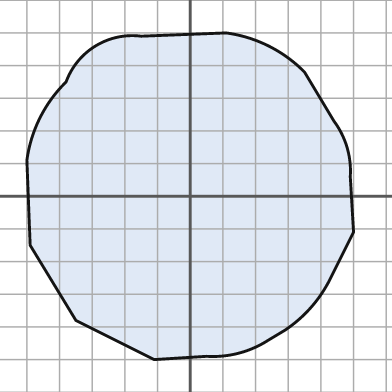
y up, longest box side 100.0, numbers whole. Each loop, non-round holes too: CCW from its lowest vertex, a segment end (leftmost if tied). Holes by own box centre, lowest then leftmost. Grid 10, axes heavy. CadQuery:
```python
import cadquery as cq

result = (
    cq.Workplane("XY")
    .moveTo(-11.0, -50.0)
    .lineTo(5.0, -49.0)
    .threePointArc((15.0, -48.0), (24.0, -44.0))
    .lineTo(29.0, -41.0)
    .threePointArc((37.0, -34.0), (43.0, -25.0))
    .lineTo(50.0, -11.0)
    .lineTo(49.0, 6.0)
    .threePointArc((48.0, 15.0), (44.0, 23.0))
    .lineTo(35.0, 38.0)
    .threePointArc((24.0, 46.0), (11.0, 50.0))
    .lineTo(-15.0, 49.0)
    .threePointArc((-29.0, 46.0), (-38.0, 35.0))
    .threePointArc((-46.0, 24.0), (-50.0, 11.0))
    .lineTo(-49.0, -15.0)
    .lineTo(-35.0, -38.0)
    .close()
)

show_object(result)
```